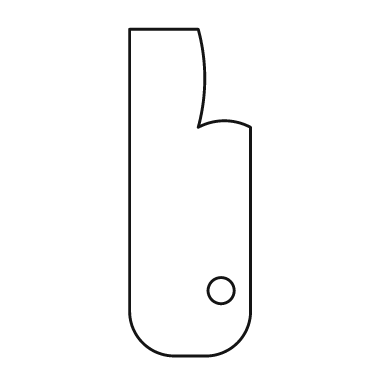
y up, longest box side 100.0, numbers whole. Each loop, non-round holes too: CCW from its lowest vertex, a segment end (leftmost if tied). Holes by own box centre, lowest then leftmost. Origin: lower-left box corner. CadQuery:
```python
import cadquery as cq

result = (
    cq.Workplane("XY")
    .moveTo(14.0, 0.0)
    .lineTo(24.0, 0.0)
    .threePointArc((33.0, 4.0), (37.0, 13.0))
    .lineTo(37.0, 70.0)
    .threePointArc((29.0, 72.0), (21.0, 70.0))
    .threePointArc((23.0, 85.0), (21.0, 100.0))
    .lineTo(0.0, 100.0)
    .lineTo(0.0, 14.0)
    .threePointArc((4.0, 4.0), (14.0, 0.0))
    .close()
    .moveTo(28.0, 20.0)
    .circle(4.0)
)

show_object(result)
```